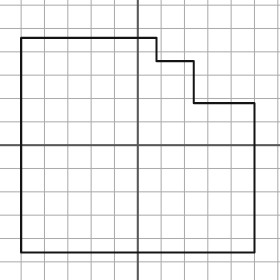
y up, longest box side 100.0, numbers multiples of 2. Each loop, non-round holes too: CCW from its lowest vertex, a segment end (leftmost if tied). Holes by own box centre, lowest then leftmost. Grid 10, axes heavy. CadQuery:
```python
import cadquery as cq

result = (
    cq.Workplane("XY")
    .moveTo(-50.0, -46.0)
    .lineTo(50.0, -46.0)
    .lineTo(50.0, 18.0)
    .lineTo(24.0, 18.0)
    .lineTo(24.0, 36.0)
    .lineTo(8.0, 36.0)
    .lineTo(8.0, 46.0)
    .lineTo(-50.0, 46.0)
    .close()
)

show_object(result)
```